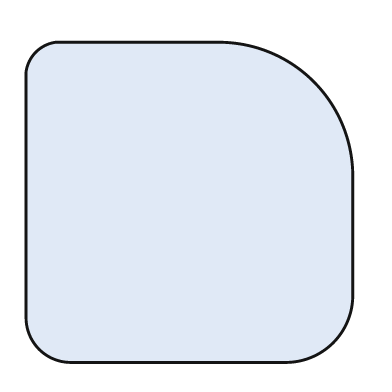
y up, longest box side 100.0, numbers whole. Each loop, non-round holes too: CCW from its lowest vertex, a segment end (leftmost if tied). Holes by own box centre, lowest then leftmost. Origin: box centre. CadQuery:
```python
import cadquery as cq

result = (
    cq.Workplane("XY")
    .moveTo(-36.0, -49.0)
    .lineTo(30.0, -49.0)
    .threePointArc((44.0, -43.0), (50.0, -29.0))
    .lineTo(50.0, 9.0)
    .threePointArc((38.0, 37.0), (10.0, 49.0))
    .lineTo(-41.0, 49.0)
    .threePointArc((-47.0, 46.0), (-50.0, 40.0))
    .lineTo(-50.0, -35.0)
    .threePointArc((-46.0, -45.0), (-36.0, -49.0))
    .close()
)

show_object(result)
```